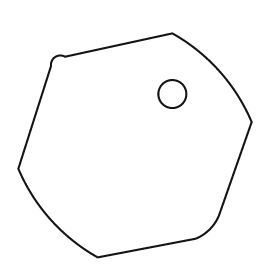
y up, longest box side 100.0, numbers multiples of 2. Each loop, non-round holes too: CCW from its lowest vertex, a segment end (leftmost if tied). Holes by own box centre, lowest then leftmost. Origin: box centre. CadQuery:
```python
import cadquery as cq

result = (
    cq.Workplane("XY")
    .moveTo(-16.0, -48.0)
    .lineTo(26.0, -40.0)
    .threePointArc((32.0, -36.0), (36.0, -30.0))
    .lineTo(50.0, 10.0)
    .threePointArc((36.0, 32.0), (16.0, 48.0))
    .lineTo(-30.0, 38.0)
    .threePointArc((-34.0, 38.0), (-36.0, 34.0))
    .lineTo(-50.0, -10.0)
    .threePointArc((-36.0, -32.0), (-16.0, -48.0))
    .close()
    .moveTo(16.0, 22.0)
    .circle(6.0)
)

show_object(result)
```